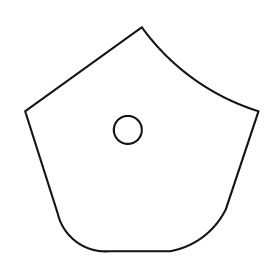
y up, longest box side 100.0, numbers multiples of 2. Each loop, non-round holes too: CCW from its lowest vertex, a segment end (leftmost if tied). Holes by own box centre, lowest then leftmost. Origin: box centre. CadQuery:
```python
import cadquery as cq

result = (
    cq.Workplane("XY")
    .moveTo(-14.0, -48.0)
    .lineTo(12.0, -48.0)
    .threePointArc((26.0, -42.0), (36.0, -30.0))
    .lineTo(50.0, 12.0)
    .threePointArc((22.0, 26.0), (0.0, 48.0))
    .lineTo(-50.0, 12.0)
    .lineTo(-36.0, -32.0)
    .threePointArc((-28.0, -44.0), (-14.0, -48.0))
    .close()
    .moveTo(-6.0, 4.0)
    .circle(6.0)
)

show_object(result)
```